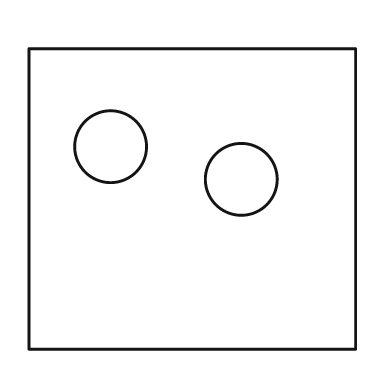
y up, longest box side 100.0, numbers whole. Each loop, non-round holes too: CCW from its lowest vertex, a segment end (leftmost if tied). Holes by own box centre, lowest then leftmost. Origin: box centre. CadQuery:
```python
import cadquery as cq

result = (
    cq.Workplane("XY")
    .moveTo(-50.0, -46.0)
    .lineTo(50.0, -46.0)
    .lineTo(50.0, 46.0)
    .lineTo(-50.0, 46.0)
    .close()
    .moveTo(15.0, 6.0)
    .circle(11.0)
    .moveTo(-25.0, 16.0)
    .circle(11.0)
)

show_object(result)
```